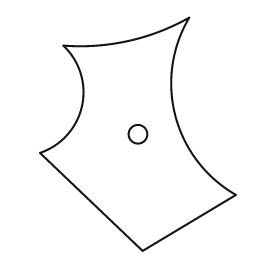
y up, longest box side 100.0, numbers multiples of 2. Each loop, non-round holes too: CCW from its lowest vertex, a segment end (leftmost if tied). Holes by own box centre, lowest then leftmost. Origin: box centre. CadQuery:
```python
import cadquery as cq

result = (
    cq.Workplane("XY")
    .moveTo(2.0, -50.0)
    .lineTo(42.0, -26.0)
    .threePointArc((16.0, 8.0), (22.0, 50.0))
    .threePointArc((-4.0, 40.0), (-32.0, 38.0))
    .threePointArc((-24.0, 12.0), (-42.0, -8.0))
    .close()
    .moveTo(0.0, 0.0)
    .circle(4.0)
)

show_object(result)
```